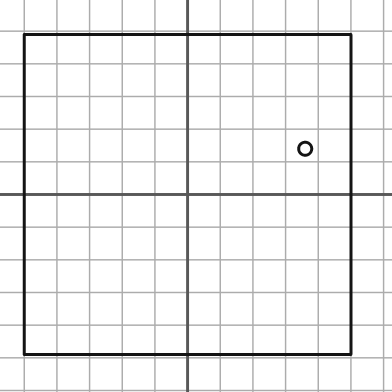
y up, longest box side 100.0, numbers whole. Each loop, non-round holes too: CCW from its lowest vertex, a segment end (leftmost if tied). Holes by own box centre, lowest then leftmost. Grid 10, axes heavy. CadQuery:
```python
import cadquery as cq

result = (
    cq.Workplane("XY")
    .moveTo(-50.0, -49.0)
    .lineTo(50.0, -49.0)
    .lineTo(50.0, 49.0)
    .lineTo(-50.0, 49.0)
    .close()
    .moveTo(36.0, 14.0)
    .circle(2.0)
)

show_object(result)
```